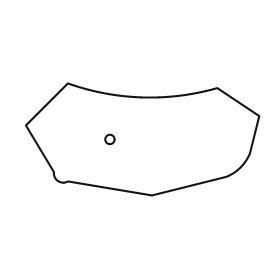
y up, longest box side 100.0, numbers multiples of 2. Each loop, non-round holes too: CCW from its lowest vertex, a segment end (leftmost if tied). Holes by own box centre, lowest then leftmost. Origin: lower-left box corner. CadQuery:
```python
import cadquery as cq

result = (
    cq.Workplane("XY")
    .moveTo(54.0, 0.0)
    .lineTo(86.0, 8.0)
    .threePointArc((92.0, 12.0), (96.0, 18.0))
    .lineTo(100.0, 34.0)
    .lineTo(82.0, 46.0)
    .threePointArc((50.0, 42.0), (18.0, 48.0))
    .lineTo(0.0, 30.0)
    .lineTo(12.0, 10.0)
    .threePointArc((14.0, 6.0), (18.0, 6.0))
    .close()
    .moveTo(36.0, 24.0)
    .circle(2.0)
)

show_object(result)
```